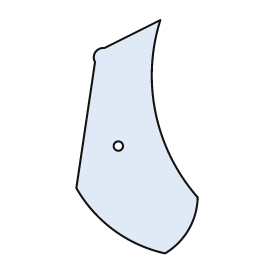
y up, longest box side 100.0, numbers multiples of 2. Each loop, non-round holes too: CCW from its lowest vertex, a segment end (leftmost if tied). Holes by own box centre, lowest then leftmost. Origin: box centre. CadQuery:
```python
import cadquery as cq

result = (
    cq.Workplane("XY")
    .moveTo(12.0, -50.0)
    .threePointArc((22.0, -40.0), (26.0, -26.0))
    .threePointArc((8.0, 10.0), (10.0, 50.0))
    .lineTo(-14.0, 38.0)
    .threePointArc((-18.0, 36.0), (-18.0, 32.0))
    .lineTo(-26.0, -22.0)
    .threePointArc((-10.0, -40.0), (12.0, -50.0))
    .close()
    .moveTo(-8.0, -4.0)
    .circle(2.0)
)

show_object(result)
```